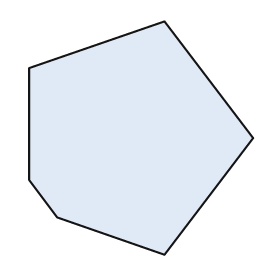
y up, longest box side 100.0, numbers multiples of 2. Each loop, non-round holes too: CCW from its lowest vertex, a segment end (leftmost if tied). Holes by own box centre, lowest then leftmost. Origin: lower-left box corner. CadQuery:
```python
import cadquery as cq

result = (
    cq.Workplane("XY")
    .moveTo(58.0, 0.0)
    .lineTo(96.0, 50.0)
    .lineTo(58.0, 100.0)
    .lineTo(0.0, 80.0)
    .lineTo(0.0, 32.0)
    .lineTo(12.0, 16.0)
    .close()
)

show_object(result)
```